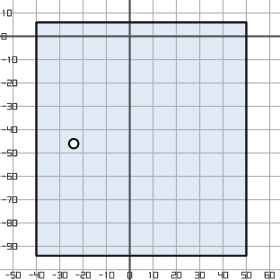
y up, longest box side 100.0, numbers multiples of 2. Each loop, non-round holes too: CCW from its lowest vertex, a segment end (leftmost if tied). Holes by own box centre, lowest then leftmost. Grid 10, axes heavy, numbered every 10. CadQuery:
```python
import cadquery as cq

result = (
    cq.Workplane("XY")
    .moveTo(-40.0, -94.0)
    .lineTo(50.0, -94.0)
    .lineTo(50.0, 6.0)
    .lineTo(-40.0, 6.0)
    .close()
    .moveTo(-24.0, -46.0)
    .circle(2.0)
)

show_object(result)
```